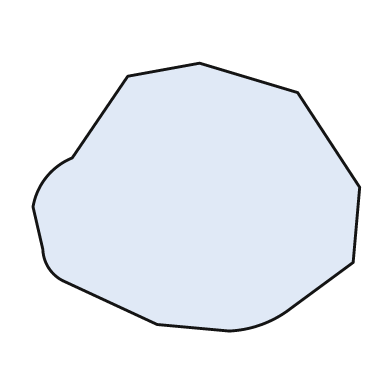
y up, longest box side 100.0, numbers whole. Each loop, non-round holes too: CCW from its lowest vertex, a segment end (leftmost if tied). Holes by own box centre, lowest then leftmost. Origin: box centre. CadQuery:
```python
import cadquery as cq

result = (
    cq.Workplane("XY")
    .moveTo(10.0, -41.0)
    .threePointArc((20.0, -39.0), (29.0, -34.0))
    .lineTo(48.0, -20.0)
    .lineTo(50.0, 3.0)
    .lineTo(31.0, 32.0)
    .lineTo(1.0, 41.0)
    .lineTo(-21.0, 37.0)
    .lineTo(-38.0, 12.0)
    .threePointArc((-46.0, 6.0), (-50.0, -3.0))
    .lineTo(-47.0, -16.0)
    .threePointArc((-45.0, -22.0), (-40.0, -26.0))
    .lineTo(-12.0, -39.0)
    .close()
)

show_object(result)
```